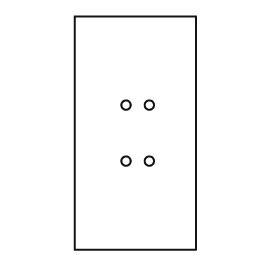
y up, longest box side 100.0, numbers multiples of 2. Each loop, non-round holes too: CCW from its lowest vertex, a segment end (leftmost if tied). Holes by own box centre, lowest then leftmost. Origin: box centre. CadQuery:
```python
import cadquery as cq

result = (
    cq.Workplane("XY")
    .moveTo(-26.0, -50.0)
    .lineTo(26.0, -50.0)
    .lineTo(26.0, 50.0)
    .lineTo(-26.0, 50.0)
    .close()
    .moveTo(-4.0, -12.0)
    .circle(2.0)
    .moveTo(6.0, -12.0)
    .circle(2.0)
    .moveTo(-4.0, 12.0)
    .circle(2.0)
    .moveTo(6.0, 12.0)
    .circle(2.0)
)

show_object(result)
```